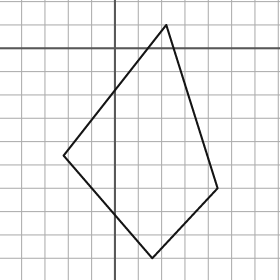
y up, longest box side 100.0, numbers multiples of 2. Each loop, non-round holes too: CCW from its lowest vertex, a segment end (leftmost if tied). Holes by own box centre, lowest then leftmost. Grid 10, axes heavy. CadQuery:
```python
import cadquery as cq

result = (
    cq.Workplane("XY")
    .moveTo(16.0, -90.0)
    .lineTo(44.0, -60.0)
    .lineTo(22.0, 10.0)
    .lineTo(-22.0, -46.0)
    .close()
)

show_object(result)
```